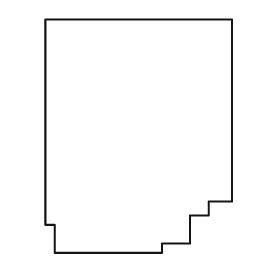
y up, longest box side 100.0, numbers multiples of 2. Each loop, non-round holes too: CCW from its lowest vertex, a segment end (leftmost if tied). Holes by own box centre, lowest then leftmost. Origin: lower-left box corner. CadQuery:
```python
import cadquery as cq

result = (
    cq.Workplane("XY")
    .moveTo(4.0, 0.0)
    .lineTo(50.0, 0.0)
    .lineTo(50.0, 4.0)
    .lineTo(62.0, 4.0)
    .lineTo(62.0, 16.0)
    .lineTo(70.0, 16.0)
    .lineTo(70.0, 22.0)
    .lineTo(80.0, 22.0)
    .lineTo(80.0, 100.0)
    .lineTo(0.0, 100.0)
    .lineTo(0.0, 12.0)
    .lineTo(4.0, 12.0)
    .close()
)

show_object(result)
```